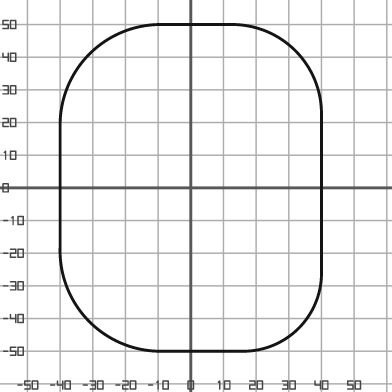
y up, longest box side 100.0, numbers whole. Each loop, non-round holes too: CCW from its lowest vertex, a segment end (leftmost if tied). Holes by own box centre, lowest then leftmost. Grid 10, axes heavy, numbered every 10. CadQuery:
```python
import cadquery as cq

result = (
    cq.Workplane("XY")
    .moveTo(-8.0, -50.0)
    .lineTo(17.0, -50.0)
    .threePointArc((33.0, -43.0), (40.0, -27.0))
    .lineTo(40.0, 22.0)
    .threePointArc((32.0, 42.0), (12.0, 50.0))
    .lineTo(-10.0, 50.0)
    .threePointArc((-31.0, 41.0), (-40.0, 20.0))
    .lineTo(-40.0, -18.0)
    .threePointArc((-31.0, -41.0), (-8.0, -50.0))
    .close()
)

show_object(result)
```